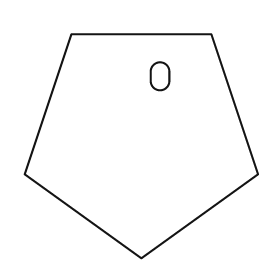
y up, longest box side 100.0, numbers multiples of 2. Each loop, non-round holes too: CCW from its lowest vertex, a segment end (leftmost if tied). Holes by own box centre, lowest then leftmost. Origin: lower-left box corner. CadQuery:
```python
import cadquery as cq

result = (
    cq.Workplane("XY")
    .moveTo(50.0, 0.0)
    .lineTo(100.0, 36.0)
    .lineTo(80.0, 96.0)
    .lineTo(20.0, 96.0)
    .lineTo(0.0, 36.0)
    .close()
    .moveTo(54.0, 76.0)
    .threePointArc((58.0, 72.0), (62.0, 76.0))
    .lineTo(62.0, 80.0)
    .threePointArc((58.0, 84.0), (54.0, 80.0))
    .close()
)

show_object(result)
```